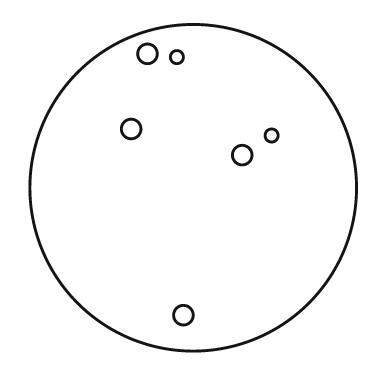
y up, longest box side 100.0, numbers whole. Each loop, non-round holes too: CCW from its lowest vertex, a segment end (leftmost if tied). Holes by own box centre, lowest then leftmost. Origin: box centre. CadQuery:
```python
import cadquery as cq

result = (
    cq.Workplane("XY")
    .moveTo(0.0, 0.0)
    .circle(50.0)
    .moveTo(-3.0, -39.0)
    .circle(3.0)
    .moveTo(15.0, 10.0)
    .circle(3.0)
    .moveTo(24.0, 16.0)
    .circle(2.0)
    .moveTo(-19.0, 18.0)
    .circle(3.0)
    .moveTo(-5.0, 40.0)
    .circle(2.0)
    .moveTo(-14.0, 41.0)
    .circle(3.0)
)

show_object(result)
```